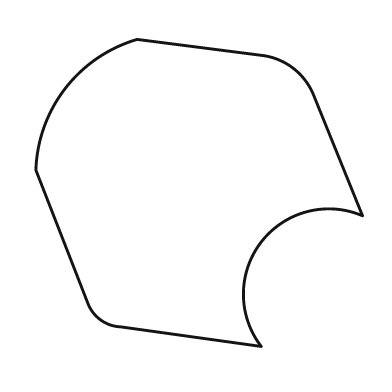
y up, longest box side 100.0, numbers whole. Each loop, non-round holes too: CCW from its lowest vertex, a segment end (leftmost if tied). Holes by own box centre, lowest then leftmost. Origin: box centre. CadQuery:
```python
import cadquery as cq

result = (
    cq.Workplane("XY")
    .moveTo(19.0, -47.0)
    .threePointArc((19.0, -15.0), (50.0, -7.0))
    .lineTo(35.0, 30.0)
    .threePointArc((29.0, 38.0), (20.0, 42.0))
    .lineTo(-19.0, 47.0)
    .threePointArc((-41.0, 32.0), (-50.0, 7.0))
    .lineTo(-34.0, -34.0)
    .threePointArc((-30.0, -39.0), (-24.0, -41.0))
    .close()
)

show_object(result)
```